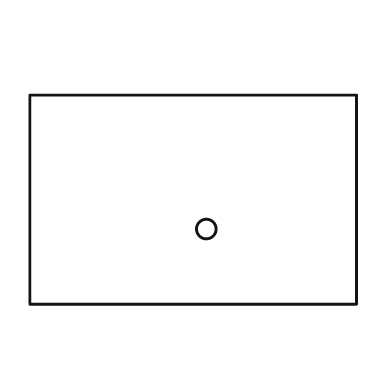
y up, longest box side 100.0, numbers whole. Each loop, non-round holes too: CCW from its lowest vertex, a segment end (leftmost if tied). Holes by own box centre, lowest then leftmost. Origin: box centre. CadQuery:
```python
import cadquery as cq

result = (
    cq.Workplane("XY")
    .moveTo(-50.0, -32.0)
    .lineTo(50.0, -32.0)
    .lineTo(50.0, 32.0)
    .lineTo(-50.0, 32.0)
    .close()
    .moveTo(4.0, -9.0)
    .circle(3.0)
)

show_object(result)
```